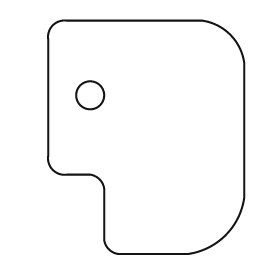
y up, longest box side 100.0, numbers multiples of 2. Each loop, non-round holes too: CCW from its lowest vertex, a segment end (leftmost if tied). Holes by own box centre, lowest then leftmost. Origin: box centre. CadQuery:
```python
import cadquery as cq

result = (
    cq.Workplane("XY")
    .moveTo(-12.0, -50.0)
    .lineTo(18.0, -50.0)
    .threePointArc((34.0, -42.0), (42.0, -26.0))
    .lineTo(42.0, 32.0)
    .threePointArc((36.0, 44.0), (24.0, 50.0))
    .lineTo(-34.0, 50.0)
    .threePointArc((-40.0, 48.0), (-42.0, 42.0))
    .lineTo(-42.0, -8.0)
    .threePointArc((-40.0, -14.0), (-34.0, -16.0))
    .lineTo(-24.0, -16.0)
    .threePointArc((-20.0, -18.0), (-18.0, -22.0))
    .lineTo(-18.0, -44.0)
    .threePointArc((-16.0, -48.0), (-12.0, -50.0))
    .close()
    .moveTo(-24.0, 18.0)
    .circle(6.0)
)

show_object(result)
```